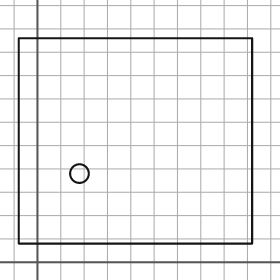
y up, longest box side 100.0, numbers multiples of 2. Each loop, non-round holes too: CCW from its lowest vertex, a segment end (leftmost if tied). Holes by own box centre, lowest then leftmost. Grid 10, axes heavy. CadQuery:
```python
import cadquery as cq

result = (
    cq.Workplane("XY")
    .moveTo(-8.0, 8.0)
    .lineTo(92.0, 8.0)
    .lineTo(92.0, 96.0)
    .lineTo(-8.0, 96.0)
    .close()
    .moveTo(18.0, 38.0)
    .circle(4.0)
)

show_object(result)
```